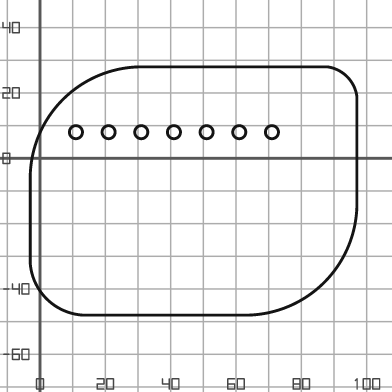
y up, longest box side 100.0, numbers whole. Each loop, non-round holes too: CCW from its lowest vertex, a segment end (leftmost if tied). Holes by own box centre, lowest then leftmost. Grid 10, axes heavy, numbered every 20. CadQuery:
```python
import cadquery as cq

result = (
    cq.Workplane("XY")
    .moveTo(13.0, -48.0)
    .lineTo(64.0, -48.0)
    .threePointArc((87.0, -38.0), (97.0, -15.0))
    .lineTo(97.0, 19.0)
    .threePointArc((94.0, 25.0), (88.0, 28.0))
    .lineTo(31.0, 28.0)
    .threePointArc((7.0, 18.0), (-3.0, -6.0))
    .lineTo(-3.0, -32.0)
    .threePointArc((2.0, -43.0), (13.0, -48.0))
    .close()
    .moveTo(11.0, 8.0)
    .circle(2.0)
    .moveTo(21.0, 8.0)
    .circle(2.0)
    .moveTo(31.0, 8.0)
    .circle(2.0)
    .moveTo(41.0, 8.0)
    .circle(2.0)
    .moveTo(51.0, 8.0)
    .circle(2.0)
    .moveTo(61.0, 8.0)
    .circle(2.0)
    .moveTo(71.0, 8.0)
    .circle(2.0)
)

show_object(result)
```